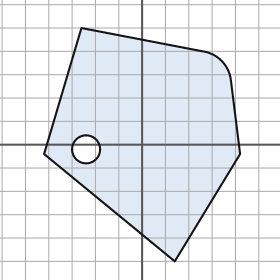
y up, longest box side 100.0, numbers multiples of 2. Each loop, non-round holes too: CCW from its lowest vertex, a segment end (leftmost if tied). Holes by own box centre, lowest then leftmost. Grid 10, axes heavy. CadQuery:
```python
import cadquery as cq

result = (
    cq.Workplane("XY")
    .moveTo(14.0, -50.0)
    .lineTo(42.0, -4.0)
    .lineTo(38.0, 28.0)
    .threePointArc((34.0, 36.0), (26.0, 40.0))
    .lineTo(-26.0, 50.0)
    .lineTo(-42.0, -4.0)
    .close()
    .moveTo(-24.0, -2.0)
    .circle(6.0)
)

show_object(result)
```